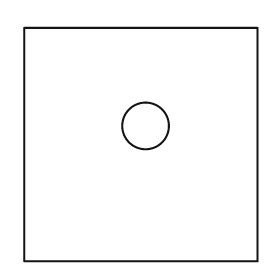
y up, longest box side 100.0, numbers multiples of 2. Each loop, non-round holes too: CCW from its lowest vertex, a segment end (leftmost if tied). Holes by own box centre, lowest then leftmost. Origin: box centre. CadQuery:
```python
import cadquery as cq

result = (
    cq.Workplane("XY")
    .moveTo(-50.0, -50.0)
    .lineTo(50.0, -50.0)
    .lineTo(50.0, 50.0)
    .lineTo(-50.0, 50.0)
    .close()
    .moveTo(2.0, 8.0)
    .circle(10.0)
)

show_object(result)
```